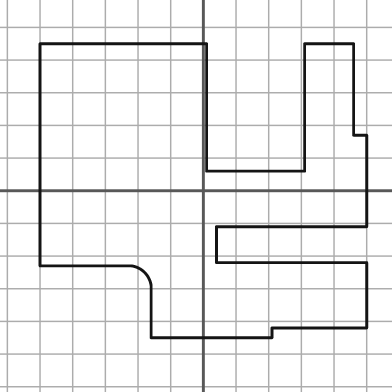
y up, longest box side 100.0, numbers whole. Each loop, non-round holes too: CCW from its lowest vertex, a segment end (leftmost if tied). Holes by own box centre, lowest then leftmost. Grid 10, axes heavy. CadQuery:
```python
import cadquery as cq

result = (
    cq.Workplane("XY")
    .moveTo(-16.0, -45.0)
    .lineTo(21.0, -45.0)
    .lineTo(21.0, -42.0)
    .lineTo(50.0, -42.0)
    .lineTo(50.0, -22.0)
    .lineTo(4.0, -22.0)
    .lineTo(4.0, -11.0)
    .lineTo(50.0, -11.0)
    .lineTo(50.0, 17.0)
    .lineTo(46.0, 17.0)
    .lineTo(46.0, 45.0)
    .lineTo(31.0, 45.0)
    .lineTo(31.0, 6.0)
    .lineTo(1.0, 6.0)
    .lineTo(1.0, 45.0)
    .lineTo(-50.0, 45.0)
    .lineTo(-50.0, -23.0)
    .lineTo(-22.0, -23.0)
    .threePointArc((-18.0, -25.0), (-16.0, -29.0))
    .close()
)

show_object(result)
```